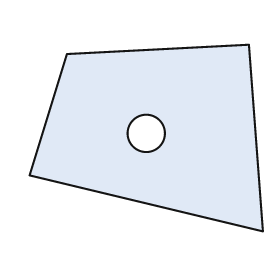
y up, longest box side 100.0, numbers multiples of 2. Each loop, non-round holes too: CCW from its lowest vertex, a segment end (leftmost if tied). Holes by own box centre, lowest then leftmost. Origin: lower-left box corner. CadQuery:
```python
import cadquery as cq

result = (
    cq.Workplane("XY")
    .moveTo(100.0, 0.0)
    .lineTo(94.0, 80.0)
    .lineTo(16.0, 76.0)
    .lineTo(0.0, 24.0)
    .close()
    .moveTo(50.0, 42.0)
    .circle(8.0)
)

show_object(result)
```